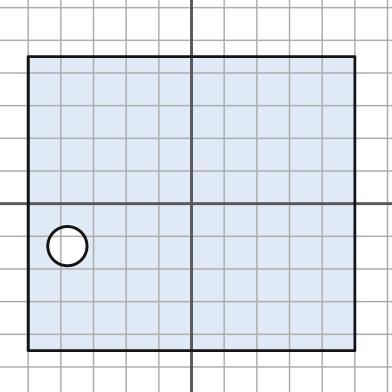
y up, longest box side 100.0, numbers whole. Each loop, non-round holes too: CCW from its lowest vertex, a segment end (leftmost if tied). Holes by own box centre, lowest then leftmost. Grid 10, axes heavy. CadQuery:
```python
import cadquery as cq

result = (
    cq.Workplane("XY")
    .moveTo(-50.0, -45.0)
    .lineTo(50.0, -45.0)
    .lineTo(50.0, 45.0)
    .lineTo(-50.0, 45.0)
    .close()
    .moveTo(-38.0, -13.0)
    .circle(6.0)
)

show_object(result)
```